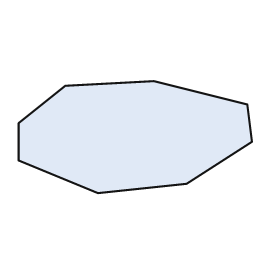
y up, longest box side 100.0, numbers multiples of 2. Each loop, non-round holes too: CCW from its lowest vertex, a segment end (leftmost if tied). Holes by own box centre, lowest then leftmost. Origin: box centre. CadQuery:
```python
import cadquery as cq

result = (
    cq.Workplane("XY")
    .moveTo(-16.0, -24.0)
    .lineTo(22.0, -20.0)
    .lineTo(50.0, -2.0)
    .lineTo(48.0, 14.0)
    .lineTo(8.0, 24.0)
    .lineTo(-30.0, 22.0)
    .lineTo(-50.0, 6.0)
    .lineTo(-50.0, -10.0)
    .close()
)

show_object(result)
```